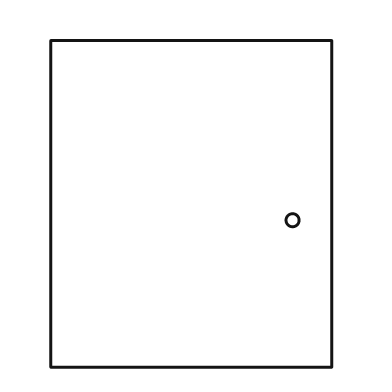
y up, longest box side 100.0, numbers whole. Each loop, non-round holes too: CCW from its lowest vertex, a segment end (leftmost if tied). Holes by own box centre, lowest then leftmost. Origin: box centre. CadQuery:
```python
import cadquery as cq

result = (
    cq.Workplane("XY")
    .moveTo(-43.0, -50.0)
    .lineTo(43.0, -50.0)
    .lineTo(43.0, 50.0)
    .lineTo(-43.0, 50.0)
    .close()
    .moveTo(31.0, -5.0)
    .circle(2.0)
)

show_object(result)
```